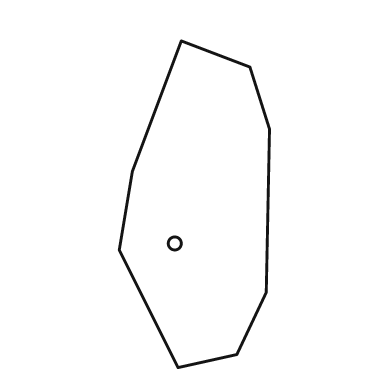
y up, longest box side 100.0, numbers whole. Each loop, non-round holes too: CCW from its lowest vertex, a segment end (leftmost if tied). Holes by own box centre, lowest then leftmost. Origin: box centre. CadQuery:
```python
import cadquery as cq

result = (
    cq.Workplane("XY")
    .moveTo(-5.0, -50.0)
    .lineTo(13.0, -46.0)
    .lineTo(22.0, -27.0)
    .lineTo(23.0, 23.0)
    .lineTo(17.0, 42.0)
    .lineTo(-4.0, 50.0)
    .lineTo(-19.0, 10.0)
    .lineTo(-23.0, -14.0)
    .close()
    .moveTo(-6.0, -12.0)
    .circle(2.0)
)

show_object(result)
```